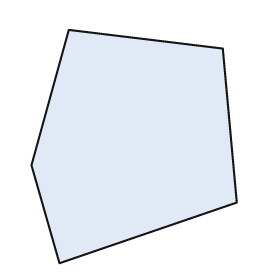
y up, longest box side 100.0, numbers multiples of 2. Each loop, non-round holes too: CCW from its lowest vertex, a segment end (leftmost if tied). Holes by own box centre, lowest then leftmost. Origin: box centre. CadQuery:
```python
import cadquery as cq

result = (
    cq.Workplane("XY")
    .moveTo(-32.0, -50.0)
    .lineTo(44.0, -24.0)
    .lineTo(38.0, 42.0)
    .lineTo(-28.0, 50.0)
    .lineTo(-44.0, -8.0)
    .close()
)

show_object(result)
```